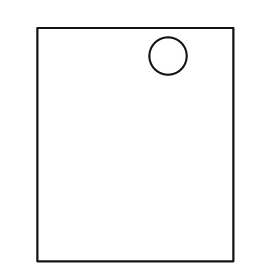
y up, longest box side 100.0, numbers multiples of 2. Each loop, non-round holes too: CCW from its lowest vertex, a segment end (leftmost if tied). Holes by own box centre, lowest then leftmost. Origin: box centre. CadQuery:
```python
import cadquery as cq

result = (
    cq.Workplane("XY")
    .moveTo(-42.0, -50.0)
    .lineTo(42.0, -50.0)
    .lineTo(42.0, 50.0)
    .lineTo(-42.0, 50.0)
    .close()
    .moveTo(14.0, 38.0)
    .circle(8.0)
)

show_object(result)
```